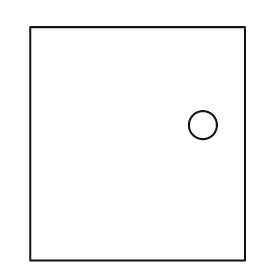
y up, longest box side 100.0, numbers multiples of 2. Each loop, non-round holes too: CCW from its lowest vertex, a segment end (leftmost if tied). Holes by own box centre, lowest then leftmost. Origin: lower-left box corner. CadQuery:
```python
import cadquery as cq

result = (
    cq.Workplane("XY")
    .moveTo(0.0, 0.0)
    .lineTo(92.0, 0.0)
    .lineTo(92.0, 100.0)
    .lineTo(0.0, 100.0)
    .close()
    .moveTo(74.0, 58.0)
    .circle(6.0)
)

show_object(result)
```